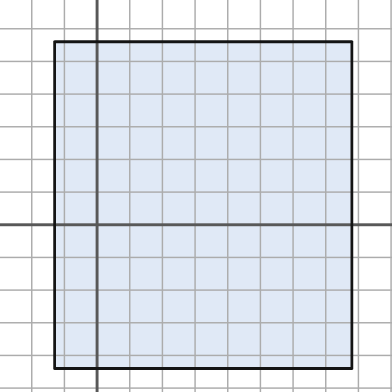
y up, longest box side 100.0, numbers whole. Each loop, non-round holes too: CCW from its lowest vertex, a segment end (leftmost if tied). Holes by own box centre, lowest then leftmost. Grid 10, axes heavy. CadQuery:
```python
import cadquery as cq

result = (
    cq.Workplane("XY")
    .moveTo(-13.0, -44.0)
    .lineTo(78.0, -44.0)
    .lineTo(78.0, 56.0)
    .lineTo(-13.0, 56.0)
    .close()
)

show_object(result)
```